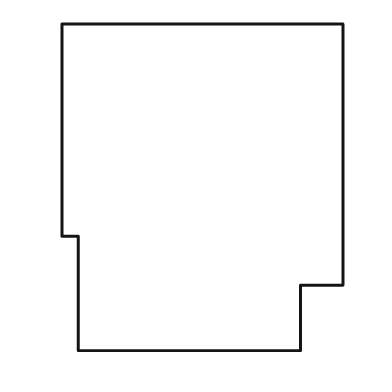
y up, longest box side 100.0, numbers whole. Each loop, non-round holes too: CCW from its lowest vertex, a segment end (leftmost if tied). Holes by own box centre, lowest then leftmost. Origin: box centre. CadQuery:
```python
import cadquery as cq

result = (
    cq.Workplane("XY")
    .moveTo(-38.0, -50.0)
    .lineTo(30.0, -50.0)
    .lineTo(30.0, -30.0)
    .lineTo(43.0, -30.0)
    .lineTo(43.0, 50.0)
    .lineTo(-43.0, 50.0)
    .lineTo(-43.0, -15.0)
    .lineTo(-38.0, -15.0)
    .close()
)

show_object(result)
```